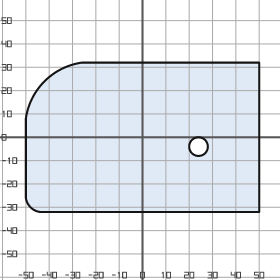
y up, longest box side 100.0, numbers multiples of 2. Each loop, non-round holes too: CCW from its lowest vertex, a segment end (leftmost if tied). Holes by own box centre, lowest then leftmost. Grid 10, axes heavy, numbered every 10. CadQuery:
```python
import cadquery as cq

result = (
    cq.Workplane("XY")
    .moveTo(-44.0, -32.0)
    .lineTo(50.0, -32.0)
    .lineTo(50.0, 32.0)
    .lineTo(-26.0, 32.0)
    .threePointArc((-42.0, 24.0), (-50.0, 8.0))
    .lineTo(-50.0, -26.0)
    .threePointArc((-48.0, -30.0), (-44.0, -32.0))
    .close()
    .moveTo(24.0, -4.0)
    .circle(4.0)
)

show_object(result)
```